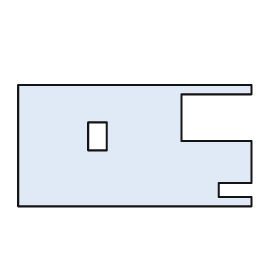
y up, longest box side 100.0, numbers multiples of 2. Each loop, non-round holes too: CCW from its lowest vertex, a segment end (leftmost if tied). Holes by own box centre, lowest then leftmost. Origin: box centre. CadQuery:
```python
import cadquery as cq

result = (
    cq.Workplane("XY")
    .moveTo(-50.0, -26.0)
    .lineTo(50.0, -26.0)
    .lineTo(50.0, -22.0)
    .lineTo(36.0, -22.0)
    .lineTo(36.0, -16.0)
    .lineTo(50.0, -16.0)
    .lineTo(50.0, 2.0)
    .lineTo(20.0, 2.0)
    .lineTo(20.0, 22.0)
    .lineTo(50.0, 22.0)
    .lineTo(50.0, 26.0)
    .lineTo(-50.0, 26.0)
    .close()
    .moveTo(-20.0, -2.0)
    .lineTo(-12.0, -2.0)
    .lineTo(-12.0, 10.0)
    .lineTo(-20.0, 10.0)
    .close()
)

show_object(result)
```